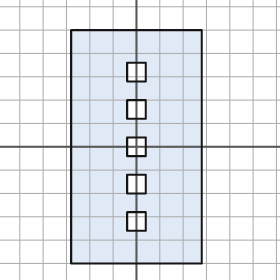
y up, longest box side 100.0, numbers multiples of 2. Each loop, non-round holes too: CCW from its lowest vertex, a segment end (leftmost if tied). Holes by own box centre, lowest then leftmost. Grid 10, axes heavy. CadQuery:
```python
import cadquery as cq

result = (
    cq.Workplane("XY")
    .moveTo(-28.0, -50.0)
    .lineTo(28.0, -50.0)
    .lineTo(28.0, 50.0)
    .lineTo(-28.0, 50.0)
    .close()
    .moveTo(-4.0, -36.0)
    .lineTo(4.0, -36.0)
    .lineTo(4.0, -28.0)
    .lineTo(-4.0, -28.0)
    .close()
    .moveTo(-4.0, -20.0)
    .lineTo(4.0, -20.0)
    .lineTo(4.0, -12.0)
    .lineTo(-4.0, -12.0)
    .close()
    .moveTo(-4.0, -4.0)
    .lineTo(4.0, -4.0)
    .lineTo(4.0, 4.0)
    .lineTo(-4.0, 4.0)
    .close()
    .moveTo(-4.0, 12.0)
    .lineTo(4.0, 12.0)
    .lineTo(4.0, 20.0)
    .lineTo(-4.0, 20.0)
    .close()
    .moveTo(-4.0, 28.0)
    .lineTo(4.0, 28.0)
    .lineTo(4.0, 36.0)
    .lineTo(-4.0, 36.0)
    .close()
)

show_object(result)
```